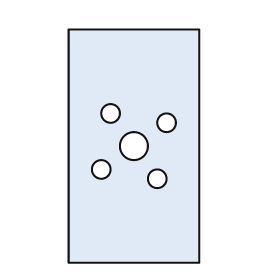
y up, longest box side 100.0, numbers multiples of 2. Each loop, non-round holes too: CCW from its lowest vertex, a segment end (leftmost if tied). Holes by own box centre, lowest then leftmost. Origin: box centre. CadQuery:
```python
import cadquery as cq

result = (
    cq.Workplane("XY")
    .moveTo(-28.0, -50.0)
    .lineTo(28.0, -50.0)
    .lineTo(28.0, 50.0)
    .lineTo(-28.0, 50.0)
    .close()
    .moveTo(10.0, -14.0)
    .circle(4.0)
    .moveTo(-14.0, -10.0)
    .circle(4.0)
    .moveTo(0.0, 0.0)
    .circle(6.0)
    .moveTo(14.0, 10.0)
    .circle(4.0)
    .moveTo(-10.0, 14.0)
    .circle(4.0)
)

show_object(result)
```